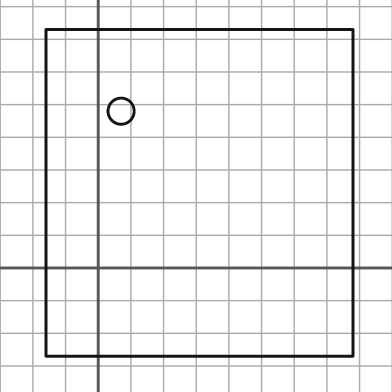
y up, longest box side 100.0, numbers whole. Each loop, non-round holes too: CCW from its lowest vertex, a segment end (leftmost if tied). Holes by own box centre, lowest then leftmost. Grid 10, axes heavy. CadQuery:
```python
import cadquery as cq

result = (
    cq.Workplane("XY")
    .moveTo(-16.0, -27.0)
    .lineTo(78.0, -27.0)
    .lineTo(78.0, 73.0)
    .lineTo(-16.0, 73.0)
    .close()
    .moveTo(7.0, 48.0)
    .circle(4.0)
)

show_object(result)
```